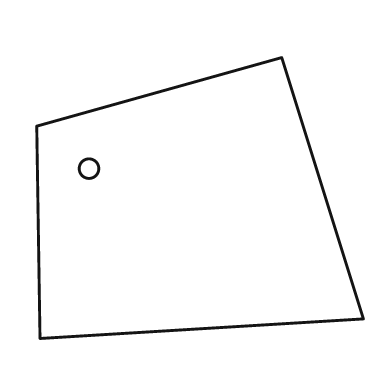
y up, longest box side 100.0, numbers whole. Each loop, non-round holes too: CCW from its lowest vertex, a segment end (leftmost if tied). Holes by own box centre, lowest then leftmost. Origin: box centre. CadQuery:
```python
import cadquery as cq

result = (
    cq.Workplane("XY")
    .moveTo(-49.0, -43.0)
    .lineTo(50.0, -37.0)
    .lineTo(25.0, 43.0)
    .lineTo(-50.0, 22.0)
    .close()
    .moveTo(-34.0, 9.0)
    .circle(3.0)
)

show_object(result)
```